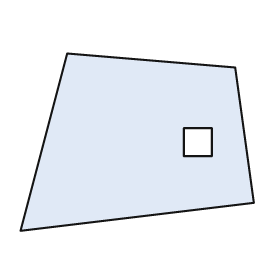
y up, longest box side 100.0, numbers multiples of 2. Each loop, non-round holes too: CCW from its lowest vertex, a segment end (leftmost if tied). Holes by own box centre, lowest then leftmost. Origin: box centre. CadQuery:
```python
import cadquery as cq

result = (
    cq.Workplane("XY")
    .moveTo(-50.0, -38.0)
    .lineTo(50.0, -26.0)
    .lineTo(42.0, 32.0)
    .lineTo(-30.0, 38.0)
    .close()
    .moveTo(20.0, -6.0)
    .lineTo(32.0, -6.0)
    .lineTo(32.0, 6.0)
    .lineTo(20.0, 6.0)
    .close()
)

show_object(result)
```